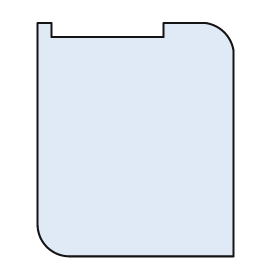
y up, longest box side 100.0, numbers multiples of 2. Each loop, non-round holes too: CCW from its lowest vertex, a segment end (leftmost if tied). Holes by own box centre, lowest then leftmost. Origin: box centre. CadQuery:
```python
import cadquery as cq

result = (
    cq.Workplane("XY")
    .moveTo(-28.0, -50.0)
    .lineTo(42.0, -50.0)
    .lineTo(42.0, 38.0)
    .threePointArc((38.0, 46.0), (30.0, 50.0))
    .lineTo(12.0, 50.0)
    .lineTo(12.0, 44.0)
    .lineTo(-36.0, 44.0)
    .lineTo(-36.0, 50.0)
    .lineTo(-42.0, 50.0)
    .lineTo(-42.0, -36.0)
    .threePointArc((-38.0, -46.0), (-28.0, -50.0))
    .close()
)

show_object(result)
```